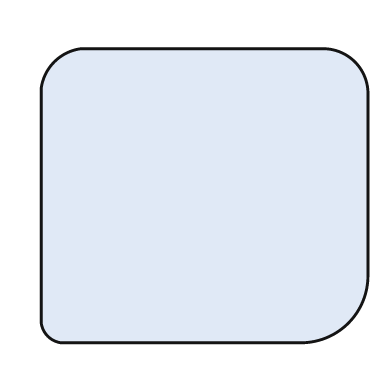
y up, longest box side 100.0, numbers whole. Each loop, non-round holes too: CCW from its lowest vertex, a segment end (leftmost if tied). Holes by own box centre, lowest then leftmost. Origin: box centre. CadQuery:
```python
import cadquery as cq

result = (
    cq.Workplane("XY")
    .moveTo(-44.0, -45.0)
    .lineTo(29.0, -45.0)
    .threePointArc((44.0, -39.0), (50.0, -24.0))
    .lineTo(50.0, 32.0)
    .threePointArc((46.0, 41.0), (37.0, 45.0))
    .lineTo(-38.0, 45.0)
    .threePointArc((-46.0, 41.0), (-50.0, 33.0))
    .lineTo(-50.0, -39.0)
    .threePointArc((-48.0, -43.0), (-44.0, -45.0))
    .close()
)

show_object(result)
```